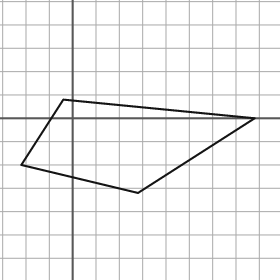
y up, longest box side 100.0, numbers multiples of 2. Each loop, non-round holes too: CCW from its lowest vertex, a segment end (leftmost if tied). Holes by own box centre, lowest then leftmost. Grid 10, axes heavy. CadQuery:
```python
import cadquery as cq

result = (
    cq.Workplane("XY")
    .moveTo(28.0, -32.0)
    .lineTo(78.0, 0.0)
    .lineTo(-4.0, 8.0)
    .lineTo(-22.0, -20.0)
    .close()
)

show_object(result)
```